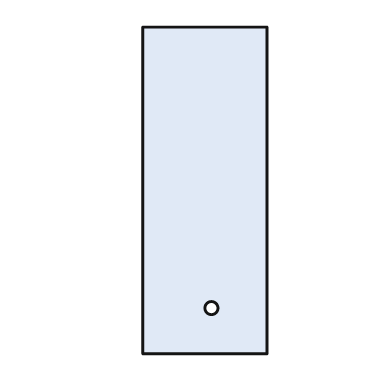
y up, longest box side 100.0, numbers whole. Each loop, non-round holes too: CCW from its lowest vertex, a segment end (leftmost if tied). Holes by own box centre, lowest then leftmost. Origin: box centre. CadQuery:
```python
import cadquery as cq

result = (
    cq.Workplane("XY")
    .moveTo(-19.0, -50.0)
    .lineTo(19.0, -50.0)
    .lineTo(19.0, 50.0)
    .lineTo(-19.0, 50.0)
    .close()
    .moveTo(2.0, -36.0)
    .circle(2.0)
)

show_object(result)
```